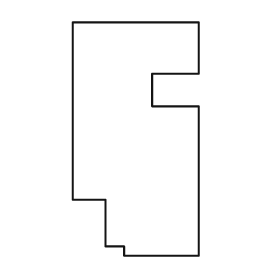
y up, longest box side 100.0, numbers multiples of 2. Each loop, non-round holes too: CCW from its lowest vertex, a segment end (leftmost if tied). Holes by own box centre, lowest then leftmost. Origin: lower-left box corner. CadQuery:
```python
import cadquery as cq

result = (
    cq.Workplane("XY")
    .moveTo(22.0, 0.0)
    .lineTo(54.0, 0.0)
    .lineTo(54.0, 64.0)
    .lineTo(34.0, 64.0)
    .lineTo(34.0, 78.0)
    .lineTo(54.0, 78.0)
    .lineTo(54.0, 100.0)
    .lineTo(0.0, 100.0)
    .lineTo(0.0, 24.0)
    .lineTo(14.0, 24.0)
    .lineTo(14.0, 4.0)
    .lineTo(22.0, 4.0)
    .close()
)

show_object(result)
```